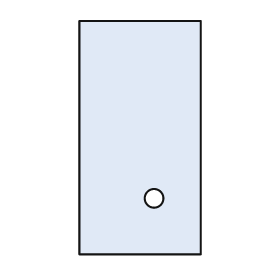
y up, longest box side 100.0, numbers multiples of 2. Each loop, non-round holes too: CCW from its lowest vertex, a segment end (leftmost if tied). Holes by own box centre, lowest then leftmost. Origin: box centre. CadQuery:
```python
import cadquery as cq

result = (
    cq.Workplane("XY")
    .moveTo(-26.0, -50.0)
    .lineTo(26.0, -50.0)
    .lineTo(26.0, 50.0)
    .lineTo(-26.0, 50.0)
    .close()
    .moveTo(6.0, -26.0)
    .circle(4.0)
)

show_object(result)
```